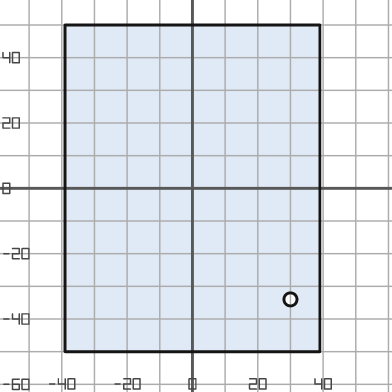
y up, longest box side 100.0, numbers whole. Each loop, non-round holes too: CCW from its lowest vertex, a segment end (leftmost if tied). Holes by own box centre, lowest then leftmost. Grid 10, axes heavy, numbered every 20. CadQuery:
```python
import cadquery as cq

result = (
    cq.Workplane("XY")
    .moveTo(-39.0, -50.0)
    .lineTo(39.0, -50.0)
    .lineTo(39.0, 50.0)
    .lineTo(-39.0, 50.0)
    .close()
    .moveTo(30.0, -34.0)
    .circle(2.0)
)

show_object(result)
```